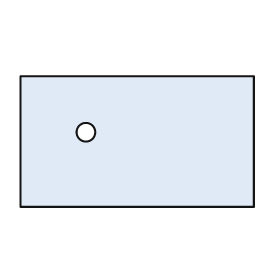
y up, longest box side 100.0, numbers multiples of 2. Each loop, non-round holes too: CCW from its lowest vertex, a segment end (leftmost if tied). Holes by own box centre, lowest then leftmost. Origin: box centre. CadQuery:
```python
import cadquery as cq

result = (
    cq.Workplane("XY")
    .moveTo(-50.0, -28.0)
    .lineTo(50.0, -28.0)
    .lineTo(50.0, 28.0)
    .lineTo(-50.0, 28.0)
    .close()
    .moveTo(-22.0, 4.0)
    .circle(4.0)
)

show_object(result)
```